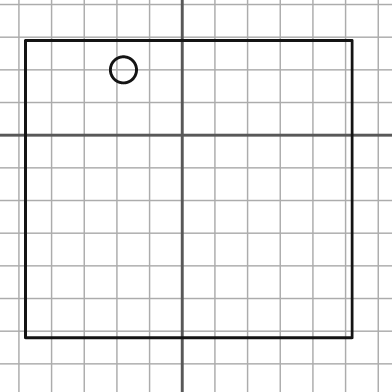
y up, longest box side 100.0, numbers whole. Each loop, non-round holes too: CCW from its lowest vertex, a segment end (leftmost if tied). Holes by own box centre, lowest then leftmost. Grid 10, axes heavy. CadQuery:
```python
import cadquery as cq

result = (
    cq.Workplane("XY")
    .moveTo(-48.0, -62.0)
    .lineTo(52.0, -62.0)
    .lineTo(52.0, 29.0)
    .lineTo(-48.0, 29.0)
    .close()
    .moveTo(-18.0, 20.0)
    .circle(4.0)
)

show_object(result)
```